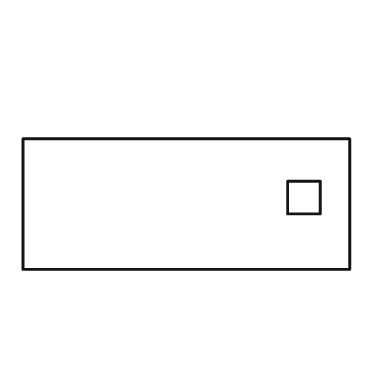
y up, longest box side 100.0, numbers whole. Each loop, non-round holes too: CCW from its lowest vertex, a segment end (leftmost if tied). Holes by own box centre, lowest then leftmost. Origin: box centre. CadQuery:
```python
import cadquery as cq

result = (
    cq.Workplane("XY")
    .moveTo(-50.0, -20.0)
    .lineTo(50.0, -20.0)
    .lineTo(50.0, 20.0)
    .lineTo(-50.0, 20.0)
    .close()
    .moveTo(31.0, -3.0)
    .lineTo(41.0, -3.0)
    .lineTo(41.0, 7.0)
    .lineTo(31.0, 7.0)
    .close()
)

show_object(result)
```